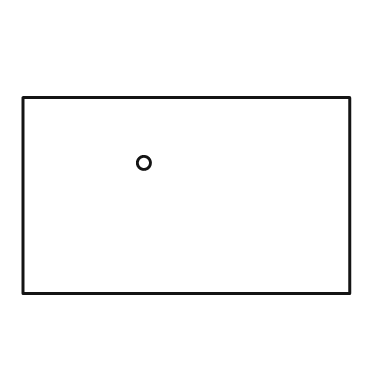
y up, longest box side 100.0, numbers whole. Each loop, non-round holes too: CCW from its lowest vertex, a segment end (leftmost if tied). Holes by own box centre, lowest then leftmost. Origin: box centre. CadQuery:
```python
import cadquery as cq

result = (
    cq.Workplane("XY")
    .moveTo(-50.0, -30.0)
    .lineTo(50.0, -30.0)
    .lineTo(50.0, 30.0)
    .lineTo(-50.0, 30.0)
    .close()
    .moveTo(-13.0, 10.0)
    .circle(2.0)
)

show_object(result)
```